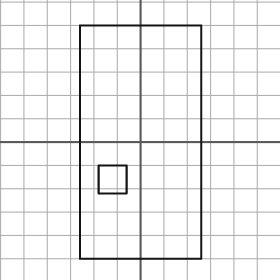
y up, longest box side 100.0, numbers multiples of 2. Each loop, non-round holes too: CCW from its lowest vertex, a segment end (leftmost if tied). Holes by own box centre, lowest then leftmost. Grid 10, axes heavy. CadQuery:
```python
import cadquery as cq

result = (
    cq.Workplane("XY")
    .moveTo(-26.0, -50.0)
    .lineTo(26.0, -50.0)
    .lineTo(26.0, 50.0)
    .lineTo(-26.0, 50.0)
    .close()
    .moveTo(-18.0, -22.0)
    .lineTo(-6.0, -22.0)
    .lineTo(-6.0, -10.0)
    .lineTo(-18.0, -10.0)
    .close()
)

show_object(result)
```